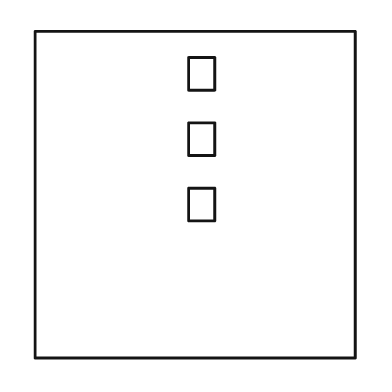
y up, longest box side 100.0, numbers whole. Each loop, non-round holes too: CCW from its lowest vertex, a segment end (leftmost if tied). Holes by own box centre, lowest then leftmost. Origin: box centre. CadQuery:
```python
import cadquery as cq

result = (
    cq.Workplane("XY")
    .moveTo(-49.0, -50.0)
    .lineTo(49.0, -50.0)
    .lineTo(49.0, 50.0)
    .lineTo(-49.0, 50.0)
    .close()
    .moveTo(-2.0, -8.0)
    .lineTo(6.0, -8.0)
    .lineTo(6.0, 2.0)
    .lineTo(-2.0, 2.0)
    .close()
    .moveTo(-2.0, 12.0)
    .lineTo(6.0, 12.0)
    .lineTo(6.0, 22.0)
    .lineTo(-2.0, 22.0)
    .close()
    .moveTo(-2.0, 32.0)
    .lineTo(6.0, 32.0)
    .lineTo(6.0, 42.0)
    .lineTo(-2.0, 42.0)
    .close()
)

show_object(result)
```